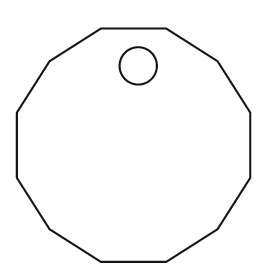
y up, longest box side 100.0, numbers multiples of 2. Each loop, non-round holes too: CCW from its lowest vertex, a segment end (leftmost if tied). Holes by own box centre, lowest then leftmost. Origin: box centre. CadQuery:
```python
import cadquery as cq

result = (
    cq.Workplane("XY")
    .moveTo(-14.0, -50.0)
    .lineTo(14.0, -50.0)
    .lineTo(36.0, -36.0)
    .lineTo(50.0, -14.0)
    .lineTo(50.0, 14.0)
    .lineTo(36.0, 36.0)
    .lineTo(14.0, 50.0)
    .lineTo(-14.0, 50.0)
    .lineTo(-36.0, 36.0)
    .lineTo(-50.0, 14.0)
    .lineTo(-50.0, -14.0)
    .lineTo(-36.0, -36.0)
    .close()
    .moveTo(2.0, 34.0)
    .circle(8.0)
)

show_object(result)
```